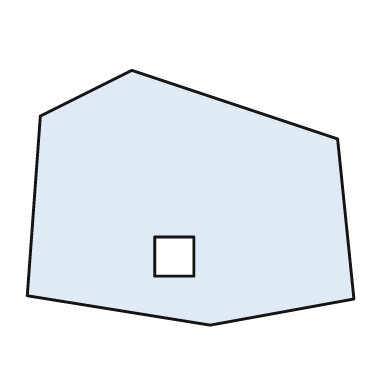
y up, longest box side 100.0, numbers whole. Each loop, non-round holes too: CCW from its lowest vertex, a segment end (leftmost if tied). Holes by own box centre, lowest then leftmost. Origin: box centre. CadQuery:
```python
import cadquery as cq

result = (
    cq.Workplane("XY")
    .moveTo(6.0, -39.0)
    .lineTo(50.0, -31.0)
    .lineTo(45.0, 18.0)
    .lineTo(-18.0, 39.0)
    .lineTo(-46.0, 25.0)
    .lineTo(-50.0, -30.0)
    .close()
    .moveTo(-11.0, -24.0)
    .lineTo(1.0, -24.0)
    .lineTo(1.0, -12.0)
    .lineTo(-11.0, -12.0)
    .close()
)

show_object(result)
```